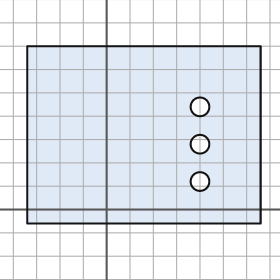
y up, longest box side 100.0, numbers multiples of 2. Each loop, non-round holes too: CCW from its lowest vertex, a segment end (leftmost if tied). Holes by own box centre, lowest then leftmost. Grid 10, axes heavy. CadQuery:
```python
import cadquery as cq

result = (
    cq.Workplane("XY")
    .moveTo(-34.0, -6.0)
    .lineTo(66.0, -6.0)
    .lineTo(66.0, 70.0)
    .lineTo(-34.0, 70.0)
    .close()
    .moveTo(40.0, 12.0)
    .circle(4.0)
    .moveTo(40.0, 28.0)
    .circle(4.0)
    .moveTo(40.0, 44.0)
    .circle(4.0)
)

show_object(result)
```